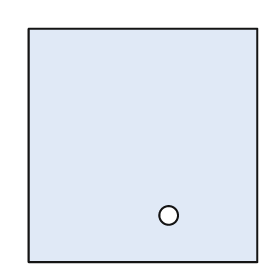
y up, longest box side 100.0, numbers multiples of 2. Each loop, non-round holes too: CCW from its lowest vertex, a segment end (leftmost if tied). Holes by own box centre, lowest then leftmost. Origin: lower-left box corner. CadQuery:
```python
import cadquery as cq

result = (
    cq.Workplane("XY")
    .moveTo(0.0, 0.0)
    .lineTo(98.0, 0.0)
    .lineTo(98.0, 100.0)
    .lineTo(0.0, 100.0)
    .close()
    .moveTo(60.0, 20.0)
    .circle(4.0)
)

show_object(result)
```